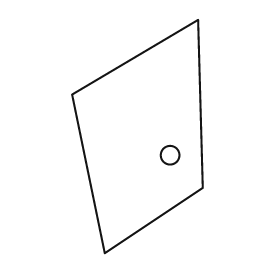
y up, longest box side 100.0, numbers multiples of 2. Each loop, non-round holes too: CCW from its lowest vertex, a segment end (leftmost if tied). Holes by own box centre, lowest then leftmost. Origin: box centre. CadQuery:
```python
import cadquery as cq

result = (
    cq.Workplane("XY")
    .moveTo(-14.0, -50.0)
    .lineTo(28.0, -22.0)
    .lineTo(26.0, 50.0)
    .lineTo(-28.0, 18.0)
    .close()
    .moveTo(14.0, -8.0)
    .circle(4.0)
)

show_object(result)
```